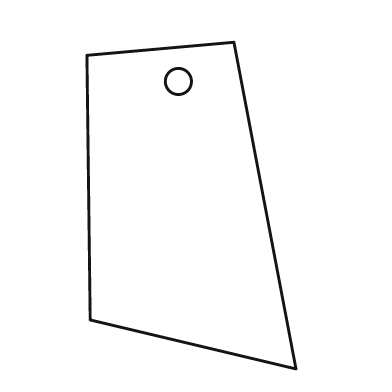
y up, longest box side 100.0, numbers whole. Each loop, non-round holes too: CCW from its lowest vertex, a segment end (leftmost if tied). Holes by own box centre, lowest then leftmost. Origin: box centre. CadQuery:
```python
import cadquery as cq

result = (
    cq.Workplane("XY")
    .moveTo(32.0, -50.0)
    .lineTo(13.0, 50.0)
    .lineTo(-32.0, 46.0)
    .lineTo(-31.0, -35.0)
    .close()
    .moveTo(-4.0, 38.0)
    .circle(4.0)
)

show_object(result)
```